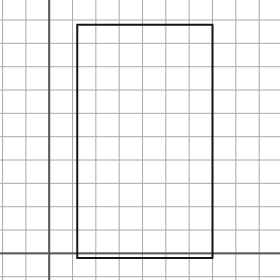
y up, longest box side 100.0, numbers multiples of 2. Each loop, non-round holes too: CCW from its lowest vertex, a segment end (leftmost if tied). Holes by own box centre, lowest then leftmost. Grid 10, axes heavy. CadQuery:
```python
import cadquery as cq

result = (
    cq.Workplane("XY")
    .moveTo(12.0, -2.0)
    .lineTo(70.0, -2.0)
    .lineTo(70.0, 98.0)
    .lineTo(12.0, 98.0)
    .close()
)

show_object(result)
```